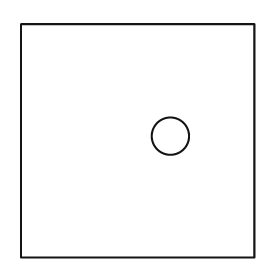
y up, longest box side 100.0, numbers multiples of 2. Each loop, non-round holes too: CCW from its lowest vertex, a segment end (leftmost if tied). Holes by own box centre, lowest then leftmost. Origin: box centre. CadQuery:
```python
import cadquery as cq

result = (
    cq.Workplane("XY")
    .moveTo(-50.0, -50.0)
    .lineTo(50.0, -50.0)
    .lineTo(50.0, 50.0)
    .lineTo(-50.0, 50.0)
    .close()
    .moveTo(14.0, 2.0)
    .circle(8.0)
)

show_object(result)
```